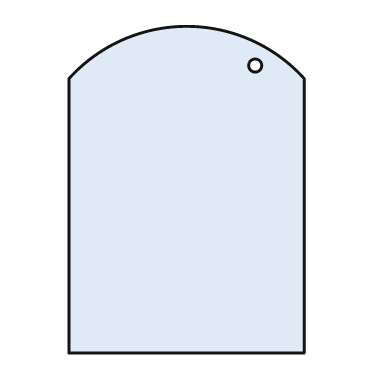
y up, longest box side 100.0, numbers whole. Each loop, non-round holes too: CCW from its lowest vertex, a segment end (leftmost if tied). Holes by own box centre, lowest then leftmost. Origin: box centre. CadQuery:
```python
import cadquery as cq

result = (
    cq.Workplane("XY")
    .moveTo(-36.0, -50.0)
    .lineTo(36.0, -50.0)
    .lineTo(36.0, 34.0)
    .threePointArc((0.0, 50.0), (-36.0, 34.0))
    .close()
    .moveTo(21.0, 38.0)
    .circle(2.0)
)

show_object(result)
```